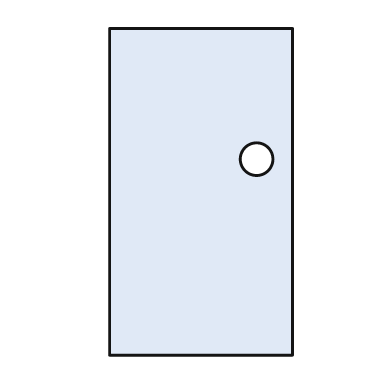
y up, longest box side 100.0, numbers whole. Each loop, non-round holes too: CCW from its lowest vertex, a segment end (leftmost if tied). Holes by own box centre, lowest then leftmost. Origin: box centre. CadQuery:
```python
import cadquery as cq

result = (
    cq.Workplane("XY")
    .moveTo(-28.0, -50.0)
    .lineTo(28.0, -50.0)
    .lineTo(28.0, 50.0)
    .lineTo(-28.0, 50.0)
    .close()
    .moveTo(17.0, 10.0)
    .circle(5.0)
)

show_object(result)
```